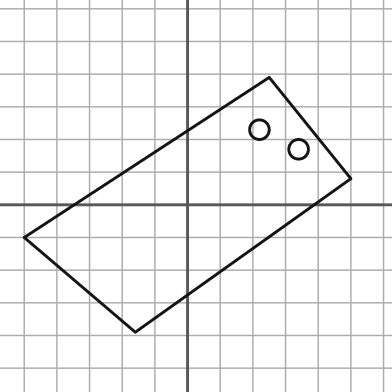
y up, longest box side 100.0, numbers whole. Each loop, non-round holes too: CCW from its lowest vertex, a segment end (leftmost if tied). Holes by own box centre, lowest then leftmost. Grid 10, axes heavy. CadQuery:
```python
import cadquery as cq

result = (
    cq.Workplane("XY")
    .moveTo(-16.0, -39.0)
    .lineTo(50.0, 8.0)
    .lineTo(25.0, 39.0)
    .lineTo(-50.0, -10.0)
    .close()
    .moveTo(34.0, 17.0)
    .circle(3.0)
    .moveTo(22.0, 23.0)
    .circle(3.0)
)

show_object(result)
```